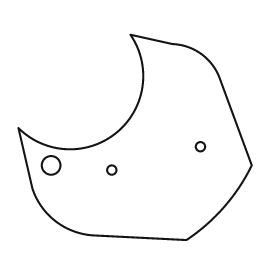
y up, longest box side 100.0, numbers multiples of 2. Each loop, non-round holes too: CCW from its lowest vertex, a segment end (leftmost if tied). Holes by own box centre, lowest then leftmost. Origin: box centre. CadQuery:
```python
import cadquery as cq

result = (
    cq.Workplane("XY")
    .moveTo(22.0, -44.0)
    .threePointArc((38.0, -30.0), (50.0, -12.0))
    .lineTo(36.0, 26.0)
    .threePointArc((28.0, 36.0), (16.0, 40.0))
    .lineTo(-2.0, 44.0)
    .threePointArc((-8.0, 2.0), (-50.0, 4.0))
    .lineTo(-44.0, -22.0)
    .threePointArc((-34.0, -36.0), (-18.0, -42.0))
    .close()
    .moveTo(-10.0, -14.0)
    .circle(2.0)
    .moveTo(-36.0, -12.0)
    .circle(4.0)
    .moveTo(28.0, -4.0)
    .circle(2.0)
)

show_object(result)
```